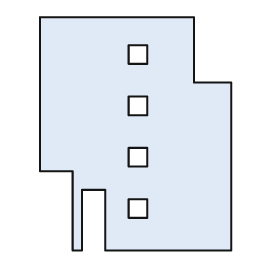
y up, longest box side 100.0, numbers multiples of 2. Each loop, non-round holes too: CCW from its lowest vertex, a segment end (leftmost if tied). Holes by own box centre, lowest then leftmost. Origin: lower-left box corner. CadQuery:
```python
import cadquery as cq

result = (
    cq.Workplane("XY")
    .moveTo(14.0, 0.0)
    .lineTo(18.0, 0.0)
    .lineTo(18.0, 26.0)
    .lineTo(28.0, 26.0)
    .lineTo(28.0, 0.0)
    .lineTo(82.0, 0.0)
    .lineTo(82.0, 72.0)
    .lineTo(66.0, 72.0)
    .lineTo(66.0, 100.0)
    .lineTo(0.0, 100.0)
    .lineTo(0.0, 34.0)
    .lineTo(14.0, 34.0)
    .close()
    .moveTo(38.0, 14.0)
    .lineTo(46.0, 14.0)
    .lineTo(46.0, 22.0)
    .lineTo(38.0, 22.0)
    .close()
    .moveTo(38.0, 36.0)
    .lineTo(46.0, 36.0)
    .lineTo(46.0, 44.0)
    .lineTo(38.0, 44.0)
    .close()
    .moveTo(38.0, 58.0)
    .lineTo(46.0, 58.0)
    .lineTo(46.0, 66.0)
    .lineTo(38.0, 66.0)
    .close()
    .moveTo(38.0, 80.0)
    .lineTo(46.0, 80.0)
    .lineTo(46.0, 88.0)
    .lineTo(38.0, 88.0)
    .close()
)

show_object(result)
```